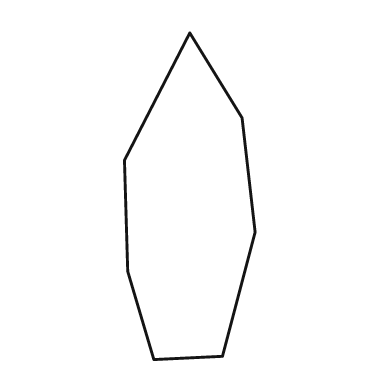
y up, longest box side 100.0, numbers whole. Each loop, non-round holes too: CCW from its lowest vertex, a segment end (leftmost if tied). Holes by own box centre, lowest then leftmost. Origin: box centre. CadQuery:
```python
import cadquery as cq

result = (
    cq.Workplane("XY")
    .moveTo(-11.0, -50.0)
    .lineTo(10.0, -49.0)
    .lineTo(20.0, -11.0)
    .lineTo(16.0, 24.0)
    .lineTo(0.0, 50.0)
    .lineTo(-20.0, 11.0)
    .lineTo(-19.0, -23.0)
    .close()
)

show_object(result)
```